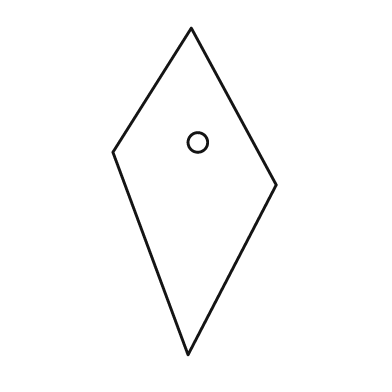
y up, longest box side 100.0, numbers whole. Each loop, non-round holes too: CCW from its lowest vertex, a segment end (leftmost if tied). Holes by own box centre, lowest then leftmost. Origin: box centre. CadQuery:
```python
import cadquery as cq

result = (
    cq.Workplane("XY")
    .moveTo(-2.0, -50.0)
    .lineTo(25.0, 2.0)
    .lineTo(-1.0, 50.0)
    .lineTo(-25.0, 12.0)
    .close()
    .moveTo(1.0, 15.0)
    .circle(3.0)
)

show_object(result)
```